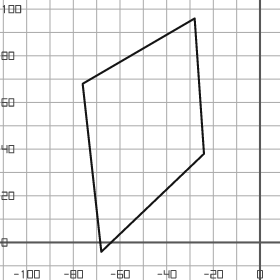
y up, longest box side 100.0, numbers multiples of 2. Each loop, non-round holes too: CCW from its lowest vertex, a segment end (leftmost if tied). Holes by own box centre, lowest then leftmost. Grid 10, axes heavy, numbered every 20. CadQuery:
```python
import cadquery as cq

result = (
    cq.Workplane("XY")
    .moveTo(-68.0, -4.0)
    .lineTo(-24.0, 38.0)
    .lineTo(-28.0, 96.0)
    .lineTo(-76.0, 68.0)
    .close()
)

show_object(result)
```